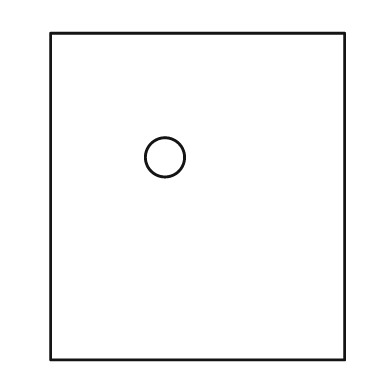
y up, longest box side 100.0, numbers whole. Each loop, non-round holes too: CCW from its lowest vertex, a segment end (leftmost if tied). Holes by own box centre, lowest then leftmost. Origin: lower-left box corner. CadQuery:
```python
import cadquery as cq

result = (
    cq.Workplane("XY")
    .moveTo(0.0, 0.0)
    .lineTo(90.0, 0.0)
    .lineTo(90.0, 100.0)
    .lineTo(0.0, 100.0)
    .close()
    .moveTo(35.0, 62.0)
    .circle(6.0)
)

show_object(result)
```